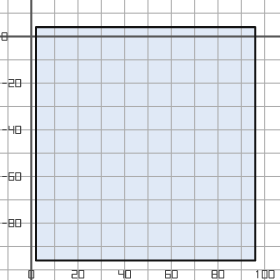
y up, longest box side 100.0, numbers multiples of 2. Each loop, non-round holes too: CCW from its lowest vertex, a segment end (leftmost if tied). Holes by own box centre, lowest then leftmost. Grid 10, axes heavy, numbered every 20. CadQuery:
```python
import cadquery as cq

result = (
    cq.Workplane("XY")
    .moveTo(2.0, -96.0)
    .lineTo(96.0, -96.0)
    .lineTo(96.0, 4.0)
    .lineTo(2.0, 4.0)
    .close()
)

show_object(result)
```